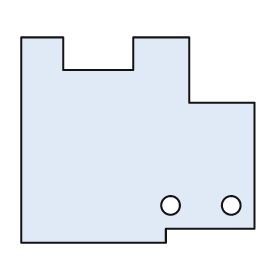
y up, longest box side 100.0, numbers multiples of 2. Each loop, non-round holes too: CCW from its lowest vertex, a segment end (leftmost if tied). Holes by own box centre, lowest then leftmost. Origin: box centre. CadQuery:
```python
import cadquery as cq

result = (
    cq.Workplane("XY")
    .moveTo(-50.0, -44.0)
    .lineTo(12.0, -44.0)
    .lineTo(12.0, -38.0)
    .lineTo(50.0, -38.0)
    .lineTo(50.0, 16.0)
    .lineTo(22.0, 16.0)
    .lineTo(22.0, 44.0)
    .lineTo(-2.0, 44.0)
    .lineTo(-2.0, 30.0)
    .lineTo(-32.0, 30.0)
    .lineTo(-32.0, 44.0)
    .lineTo(-50.0, 44.0)
    .close()
    .moveTo(14.0, -28.0)
    .circle(4.0)
    .moveTo(40.0, -28.0)
    .circle(4.0)
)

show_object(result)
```